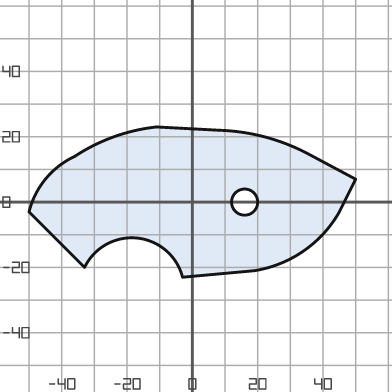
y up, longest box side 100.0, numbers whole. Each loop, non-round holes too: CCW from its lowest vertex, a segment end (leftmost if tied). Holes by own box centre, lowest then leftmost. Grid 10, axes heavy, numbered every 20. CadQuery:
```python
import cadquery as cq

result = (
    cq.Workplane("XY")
    .moveTo(-3.0, -23.0)
    .lineTo(19.0, -21.0)
    .threePointArc((34.0, -15.0), (45.0, -3.0))
    .lineTo(50.0, 7.0)
    .lineTo(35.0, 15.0)
    .threePointArc((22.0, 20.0), (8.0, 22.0))
    .lineTo(-11.0, 23.0)
    .threePointArc((-24.0, 20.0), (-36.0, 14.0))
    .threePointArc((-45.0, 7.0), (-50.0, -3.0))
    .lineTo(-33.0, -20.0)
    .threePointArc((-17.0, -11.0), (-3.0, -23.0))
    .close()
    .moveTo(16.0, 0.0)
    .circle(4.0)
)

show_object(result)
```